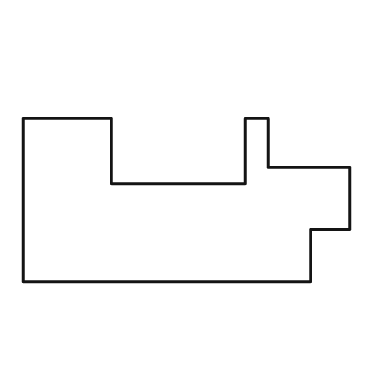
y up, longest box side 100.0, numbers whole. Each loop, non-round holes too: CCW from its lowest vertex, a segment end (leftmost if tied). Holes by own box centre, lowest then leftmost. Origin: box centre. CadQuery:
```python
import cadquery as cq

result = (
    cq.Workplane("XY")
    .moveTo(-50.0, -25.0)
    .lineTo(38.0, -25.0)
    .lineTo(38.0, -9.0)
    .lineTo(50.0, -9.0)
    .lineTo(50.0, 10.0)
    .lineTo(25.0, 10.0)
    .lineTo(25.0, 25.0)
    .lineTo(18.0, 25.0)
    .lineTo(18.0, 5.0)
    .lineTo(-23.0, 5.0)
    .lineTo(-23.0, 25.0)
    .lineTo(-50.0, 25.0)
    .close()
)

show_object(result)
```